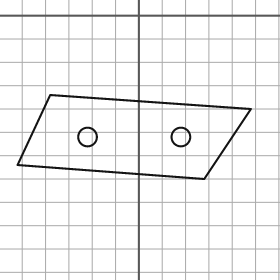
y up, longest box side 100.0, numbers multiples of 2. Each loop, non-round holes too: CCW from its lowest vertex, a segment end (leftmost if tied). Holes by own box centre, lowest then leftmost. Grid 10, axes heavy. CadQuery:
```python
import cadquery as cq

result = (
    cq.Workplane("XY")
    .moveTo(28.0, -70.0)
    .lineTo(48.0, -40.0)
    .lineTo(-38.0, -34.0)
    .lineTo(-52.0, -64.0)
    .close()
    .moveTo(-22.0, -52.0)
    .circle(4.0)
    .moveTo(18.0, -52.0)
    .circle(4.0)
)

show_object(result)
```